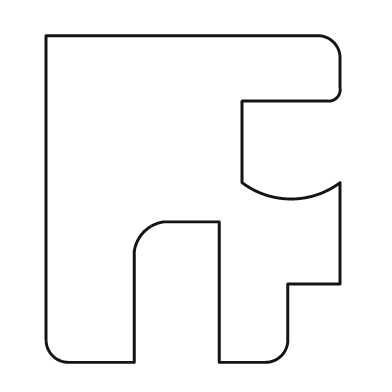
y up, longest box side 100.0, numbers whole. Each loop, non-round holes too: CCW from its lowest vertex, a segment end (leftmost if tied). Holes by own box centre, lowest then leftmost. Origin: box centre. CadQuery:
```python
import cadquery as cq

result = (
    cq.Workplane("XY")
    .moveTo(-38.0, -50.0)
    .lineTo(-18.0, -50.0)
    .lineTo(-18.0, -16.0)
    .threePointArc((-15.0, -10.0), (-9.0, -7.0))
    .lineTo(8.0, -7.0)
    .lineTo(8.0, -50.0)
    .lineTo(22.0, -50.0)
    .threePointArc((27.0, -48.0), (29.0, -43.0))
    .lineTo(29.0, -26.0)
    .lineTo(45.0, -26.0)
    .lineTo(45.0, 5.0)
    .threePointArc((30.0, 0.0), (15.0, 5.0))
    .lineTo(15.0, 30.0)
    .lineTo(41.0, 30.0)
    .threePointArc((44.0, 31.0), (45.0, 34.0))
    .lineTo(45.0, 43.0)
    .threePointArc((43.0, 48.0), (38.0, 50.0))
    .lineTo(-45.0, 50.0)
    .lineTo(-45.0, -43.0)
    .threePointArc((-43.0, -48.0), (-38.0, -50.0))
    .close()
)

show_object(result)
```